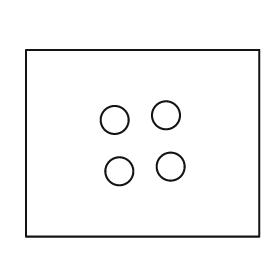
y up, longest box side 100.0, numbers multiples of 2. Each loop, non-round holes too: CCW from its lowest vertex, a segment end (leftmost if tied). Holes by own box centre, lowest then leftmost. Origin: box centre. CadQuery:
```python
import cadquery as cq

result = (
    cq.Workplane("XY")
    .moveTo(-50.0, -40.0)
    .lineTo(50.0, -40.0)
    .lineTo(50.0, 40.0)
    .lineTo(-50.0, 40.0)
    .close()
    .moveTo(-10.0, -12.0)
    .circle(6.0)
    .moveTo(12.0, -10.0)
    .circle(6.0)
    .moveTo(-12.0, 10.0)
    .circle(6.0)
    .moveTo(10.0, 12.0)
    .circle(6.0)
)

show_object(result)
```